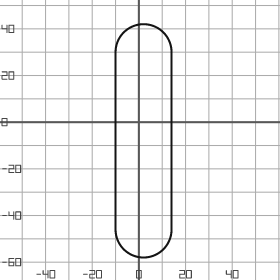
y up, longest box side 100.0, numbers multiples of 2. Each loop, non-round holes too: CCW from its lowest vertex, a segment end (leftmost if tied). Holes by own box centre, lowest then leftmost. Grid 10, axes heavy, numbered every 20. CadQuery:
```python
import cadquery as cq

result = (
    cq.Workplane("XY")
    .moveTo(-10.0, -46.0)
    .threePointArc((2.0, -58.0), (14.0, -46.0))
    .lineTo(14.0, 30.0)
    .threePointArc((2.0, 42.0), (-10.0, 30.0))
    .close()
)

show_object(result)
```